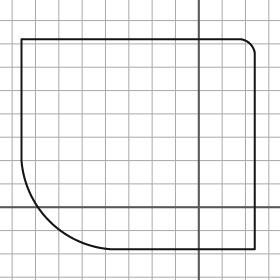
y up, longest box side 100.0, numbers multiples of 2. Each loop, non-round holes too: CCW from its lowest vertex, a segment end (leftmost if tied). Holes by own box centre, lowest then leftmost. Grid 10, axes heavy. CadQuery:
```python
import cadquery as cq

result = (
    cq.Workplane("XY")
    .moveTo(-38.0, -18.0)
    .lineTo(24.0, -18.0)
    .lineTo(24.0, 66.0)
    .threePointArc((22.0, 70.0), (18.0, 72.0))
    .lineTo(-76.0, 72.0)
    .lineTo(-76.0, 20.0)
    .threePointArc((-64.0, -6.0), (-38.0, -18.0))
    .close()
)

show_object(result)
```